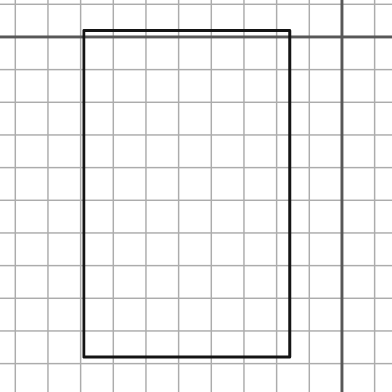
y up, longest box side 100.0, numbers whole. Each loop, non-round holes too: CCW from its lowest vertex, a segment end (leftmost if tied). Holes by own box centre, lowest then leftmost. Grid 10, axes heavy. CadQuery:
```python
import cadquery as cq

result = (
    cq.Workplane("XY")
    .moveTo(-79.0, -98.0)
    .lineTo(-16.0, -98.0)
    .lineTo(-16.0, 2.0)
    .lineTo(-79.0, 2.0)
    .close()
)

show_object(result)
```